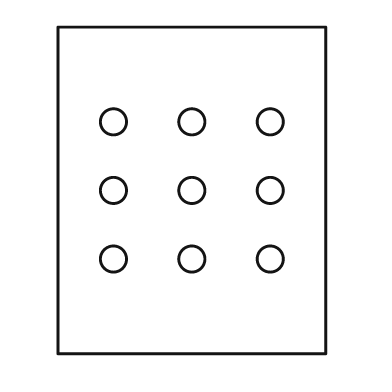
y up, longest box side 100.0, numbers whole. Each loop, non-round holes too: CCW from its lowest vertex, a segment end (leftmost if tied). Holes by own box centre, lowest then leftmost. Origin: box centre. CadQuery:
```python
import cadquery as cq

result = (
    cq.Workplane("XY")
    .moveTo(-41.0, -50.0)
    .lineTo(41.0, -50.0)
    .lineTo(41.0, 50.0)
    .lineTo(-41.0, 50.0)
    .close()
    .moveTo(-24.0, -21.0)
    .circle(4.0)
    .moveTo(0.0, -21.0)
    .circle(4.0)
    .moveTo(24.0, -21.0)
    .circle(4.0)
    .moveTo(-24.0, 0.0)
    .circle(4.0)
    .moveTo(0.0, 0.0)
    .circle(4.0)
    .moveTo(24.0, 0.0)
    .circle(4.0)
    .moveTo(-24.0, 21.0)
    .circle(4.0)
    .moveTo(0.0, 21.0)
    .circle(4.0)
    .moveTo(24.0, 21.0)
    .circle(4.0)
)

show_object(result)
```